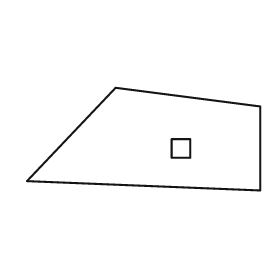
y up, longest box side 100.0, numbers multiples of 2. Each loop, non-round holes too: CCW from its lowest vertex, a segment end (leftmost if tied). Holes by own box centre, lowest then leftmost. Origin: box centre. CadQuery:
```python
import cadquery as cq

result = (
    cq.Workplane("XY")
    .moveTo(50.0, -22.0)
    .lineTo(50.0, 14.0)
    .lineTo(-12.0, 22.0)
    .lineTo(-50.0, -18.0)
    .close()
    .moveTo(12.0, -8.0)
    .lineTo(20.0, -8.0)
    .lineTo(20.0, 0.0)
    .lineTo(12.0, 0.0)
    .close()
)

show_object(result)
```